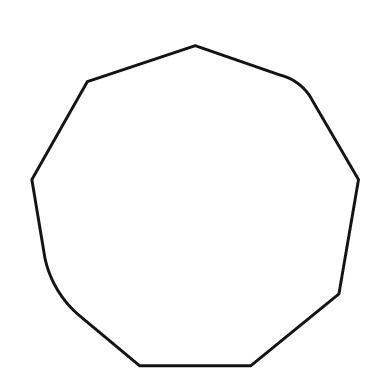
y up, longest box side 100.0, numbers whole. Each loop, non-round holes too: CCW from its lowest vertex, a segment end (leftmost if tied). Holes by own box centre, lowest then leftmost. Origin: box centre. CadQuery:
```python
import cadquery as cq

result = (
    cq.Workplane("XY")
    .moveTo(-17.0, -49.0)
    .lineTo(17.0, -49.0)
    .lineTo(44.0, -27.0)
    .lineTo(50.0, 8.0)
    .lineTo(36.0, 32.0)
    .threePointArc((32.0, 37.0), (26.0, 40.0))
    .lineTo(0.0, 49.0)
    .lineTo(-33.0, 38.0)
    .lineTo(-50.0, 8.0)
    .lineTo(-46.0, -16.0)
    .threePointArc((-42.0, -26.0), (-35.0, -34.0))
    .close()
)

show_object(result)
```